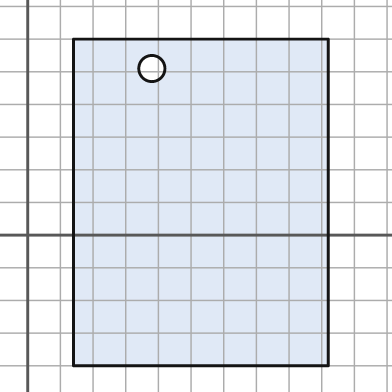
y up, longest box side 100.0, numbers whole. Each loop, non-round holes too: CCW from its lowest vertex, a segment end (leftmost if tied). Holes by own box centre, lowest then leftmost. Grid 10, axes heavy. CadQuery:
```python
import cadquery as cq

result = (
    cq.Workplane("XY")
    .moveTo(14.0, -40.0)
    .lineTo(92.0, -40.0)
    .lineTo(92.0, 60.0)
    .lineTo(14.0, 60.0)
    .close()
    .moveTo(38.0, 51.0)
    .circle(4.0)
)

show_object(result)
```